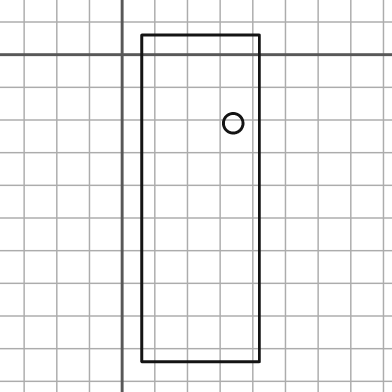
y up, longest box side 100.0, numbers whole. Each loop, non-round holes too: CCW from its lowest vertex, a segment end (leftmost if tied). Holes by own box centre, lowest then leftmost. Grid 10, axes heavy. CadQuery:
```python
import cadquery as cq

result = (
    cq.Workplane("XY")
    .moveTo(6.0, -94.0)
    .lineTo(42.0, -94.0)
    .lineTo(42.0, 6.0)
    .lineTo(6.0, 6.0)
    .close()
    .moveTo(34.0, -21.0)
    .circle(3.0)
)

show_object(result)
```